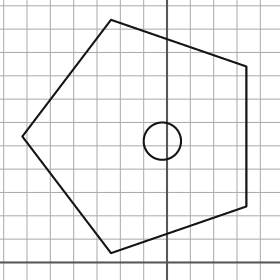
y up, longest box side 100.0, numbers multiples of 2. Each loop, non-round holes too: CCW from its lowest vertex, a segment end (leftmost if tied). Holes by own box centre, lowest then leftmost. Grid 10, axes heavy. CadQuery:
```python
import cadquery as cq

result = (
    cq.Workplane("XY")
    .moveTo(-24.0, 4.0)
    .lineTo(34.0, 24.0)
    .lineTo(34.0, 84.0)
    .lineTo(-24.0, 104.0)
    .lineTo(-62.0, 54.0)
    .close()
    .moveTo(-2.0, 52.0)
    .circle(8.0)
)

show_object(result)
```